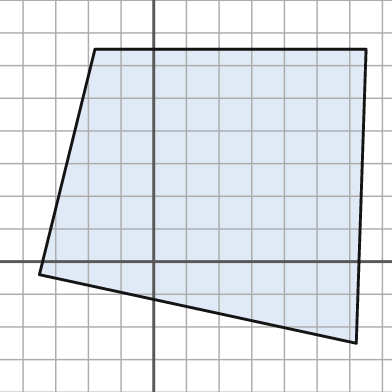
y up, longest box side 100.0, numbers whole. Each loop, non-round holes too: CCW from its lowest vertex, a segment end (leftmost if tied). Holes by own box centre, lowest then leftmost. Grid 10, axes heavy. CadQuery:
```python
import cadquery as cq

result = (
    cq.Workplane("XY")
    .moveTo(62.0, -25.0)
    .lineTo(65.0, 65.0)
    .lineTo(-18.0, 65.0)
    .lineTo(-35.0, -4.0)
    .close()
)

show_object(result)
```